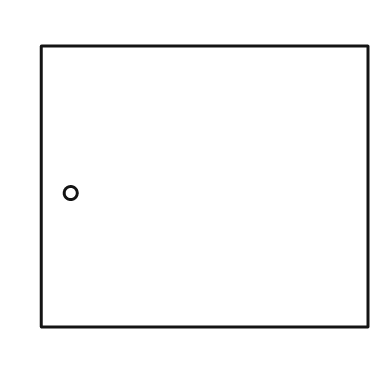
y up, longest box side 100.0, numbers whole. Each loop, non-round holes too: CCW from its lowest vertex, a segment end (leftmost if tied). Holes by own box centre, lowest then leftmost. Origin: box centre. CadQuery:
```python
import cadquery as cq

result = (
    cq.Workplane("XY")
    .moveTo(-50.0, -43.0)
    .lineTo(50.0, -43.0)
    .lineTo(50.0, 43.0)
    .lineTo(-50.0, 43.0)
    .close()
    .moveTo(-41.0, -2.0)
    .circle(2.0)
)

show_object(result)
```